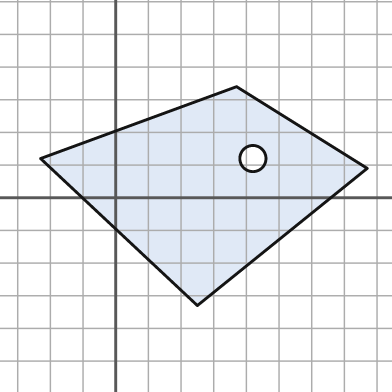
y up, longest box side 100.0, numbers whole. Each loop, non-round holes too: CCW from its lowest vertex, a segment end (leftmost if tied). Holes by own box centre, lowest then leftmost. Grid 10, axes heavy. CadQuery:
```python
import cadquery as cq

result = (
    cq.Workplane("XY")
    .moveTo(25.0, -33.0)
    .lineTo(77.0, 9.0)
    .lineTo(37.0, 34.0)
    .lineTo(-23.0, 12.0)
    .close()
    .moveTo(42.0, 12.0)
    .circle(4.0)
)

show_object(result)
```